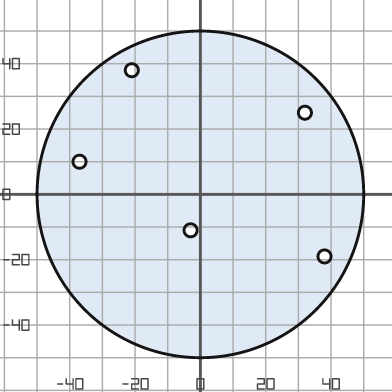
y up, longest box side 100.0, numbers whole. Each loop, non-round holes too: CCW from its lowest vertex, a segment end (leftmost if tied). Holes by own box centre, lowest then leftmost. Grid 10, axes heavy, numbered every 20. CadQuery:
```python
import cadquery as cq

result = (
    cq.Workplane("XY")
    .moveTo(0.0, 0.0)
    .circle(50.0)
    .moveTo(38.0, -19.0)
    .circle(2.0)
    .moveTo(-3.0, -11.0)
    .circle(2.0)
    .moveTo(-37.0, 10.0)
    .circle(2.0)
    .moveTo(32.0, 25.0)
    .circle(2.0)
    .moveTo(-21.0, 38.0)
    .circle(2.0)
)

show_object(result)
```